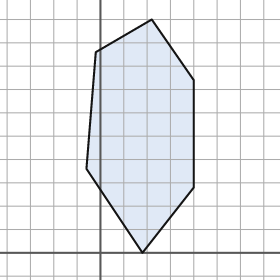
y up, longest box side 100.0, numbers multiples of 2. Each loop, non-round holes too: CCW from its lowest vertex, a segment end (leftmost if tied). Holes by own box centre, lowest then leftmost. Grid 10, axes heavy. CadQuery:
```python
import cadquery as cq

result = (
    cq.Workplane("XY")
    .moveTo(18.0, 0.0)
    .lineTo(40.0, 28.0)
    .lineTo(40.0, 74.0)
    .lineTo(22.0, 100.0)
    .lineTo(-2.0, 86.0)
    .lineTo(-6.0, 36.0)
    .close()
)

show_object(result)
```